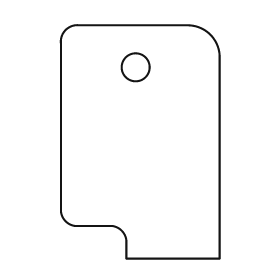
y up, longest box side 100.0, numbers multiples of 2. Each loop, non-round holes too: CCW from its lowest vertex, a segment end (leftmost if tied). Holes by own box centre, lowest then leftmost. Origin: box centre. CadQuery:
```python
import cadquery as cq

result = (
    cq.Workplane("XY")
    .moveTo(-6.0, -50.0)
    .lineTo(34.0, -50.0)
    .lineTo(34.0, 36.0)
    .threePointArc((30.0, 46.0), (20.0, 50.0))
    .lineTo(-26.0, 50.0)
    .threePointArc((-32.0, 48.0), (-34.0, 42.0))
    .lineTo(-34.0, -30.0)
    .threePointArc((-32.0, -34.0), (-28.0, -36.0))
    .lineTo(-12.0, -36.0)
    .threePointArc((-8.0, -38.0), (-6.0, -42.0))
    .close()
    .moveTo(-2.0, 32.0)
    .circle(6.0)
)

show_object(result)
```